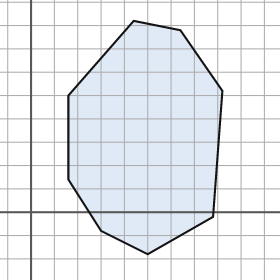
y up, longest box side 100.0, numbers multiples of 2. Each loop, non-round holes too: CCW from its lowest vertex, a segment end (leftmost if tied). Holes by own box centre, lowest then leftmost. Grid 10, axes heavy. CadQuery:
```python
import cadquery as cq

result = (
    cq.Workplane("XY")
    .moveTo(50.0, -18.0)
    .lineTo(78.0, -2.0)
    .lineTo(82.0, 52.0)
    .lineTo(64.0, 78.0)
    .lineTo(44.0, 82.0)
    .lineTo(16.0, 50.0)
    .lineTo(16.0, 14.0)
    .lineTo(30.0, -8.0)
    .close()
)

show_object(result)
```